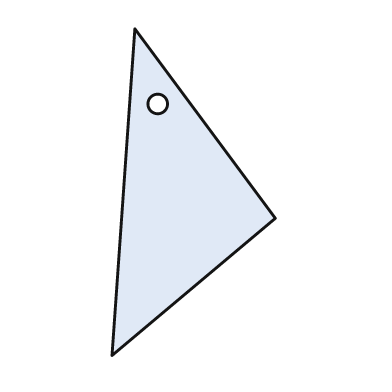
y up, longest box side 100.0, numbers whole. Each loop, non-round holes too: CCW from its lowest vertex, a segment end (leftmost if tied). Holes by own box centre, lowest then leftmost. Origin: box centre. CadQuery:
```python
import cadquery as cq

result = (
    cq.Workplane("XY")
    .moveTo(-25.0, -50.0)
    .lineTo(25.0, -8.0)
    .lineTo(-18.0, 50.0)
    .close()
    .moveTo(-11.0, 27.0)
    .circle(3.0)
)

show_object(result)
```